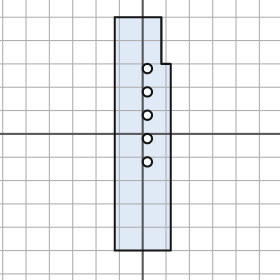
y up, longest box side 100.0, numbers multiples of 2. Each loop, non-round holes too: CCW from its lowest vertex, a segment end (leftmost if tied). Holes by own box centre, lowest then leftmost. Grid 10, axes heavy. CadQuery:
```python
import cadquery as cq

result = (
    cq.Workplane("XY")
    .moveTo(-12.0, -50.0)
    .lineTo(12.0, -50.0)
    .lineTo(12.0, 30.0)
    .lineTo(8.0, 30.0)
    .lineTo(8.0, 50.0)
    .lineTo(-12.0, 50.0)
    .close()
    .moveTo(2.0, -12.0)
    .circle(2.0)
    .moveTo(2.0, -2.0)
    .circle(2.0)
    .moveTo(2.0, 8.0)
    .circle(2.0)
    .moveTo(2.0, 18.0)
    .circle(2.0)
    .moveTo(2.0, 28.0)
    .circle(2.0)
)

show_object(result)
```